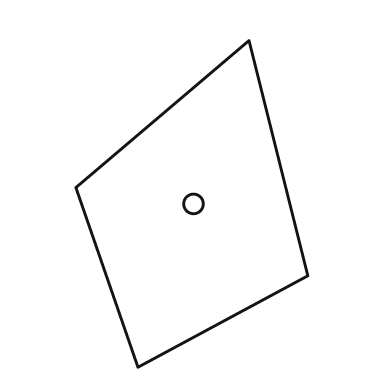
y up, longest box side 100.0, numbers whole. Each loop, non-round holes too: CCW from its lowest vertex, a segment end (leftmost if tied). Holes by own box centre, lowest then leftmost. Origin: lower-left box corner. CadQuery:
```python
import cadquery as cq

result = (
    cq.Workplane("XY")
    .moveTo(19.0, 0.0)
    .lineTo(71.0, 28.0)
    .lineTo(53.0, 100.0)
    .lineTo(0.0, 55.0)
    .close()
    .moveTo(36.0, 50.0)
    .circle(3.0)
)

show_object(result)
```